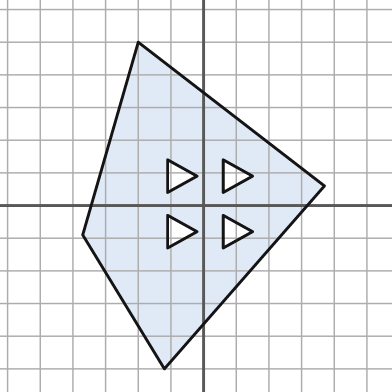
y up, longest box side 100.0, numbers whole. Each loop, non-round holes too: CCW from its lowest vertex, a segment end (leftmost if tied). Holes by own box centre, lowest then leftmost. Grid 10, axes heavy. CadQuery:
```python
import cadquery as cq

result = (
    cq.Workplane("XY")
    .moveTo(-12.0, -50.0)
    .lineTo(37.0, 6.0)
    .lineTo(-20.0, 50.0)
    .lineTo(-37.0, -9.0)
    .close()
    .moveTo(-11.0, -13.0)
    .lineTo(-2.0, -8.0)
    .lineTo(-11.0, -3.0)
    .close()
    .moveTo(6.0, -13.0)
    .lineTo(15.0, -8.0)
    .lineTo(6.0, -3.0)
    .close()
    .moveTo(-11.0, 4.0)
    .lineTo(-2.0, 9.0)
    .lineTo(-11.0, 14.0)
    .close()
    .moveTo(6.0, 4.0)
    .lineTo(15.0, 9.0)
    .lineTo(6.0, 14.0)
    .close()
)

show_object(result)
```